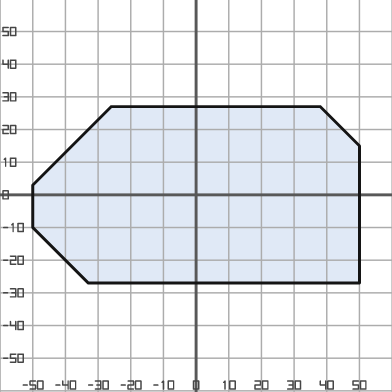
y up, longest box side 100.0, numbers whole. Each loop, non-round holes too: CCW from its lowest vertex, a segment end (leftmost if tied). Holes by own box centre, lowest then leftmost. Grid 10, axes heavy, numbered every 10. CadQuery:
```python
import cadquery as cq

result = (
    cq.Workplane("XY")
    .moveTo(-33.0, -27.0)
    .lineTo(50.0, -27.0)
    .lineTo(50.0, 15.0)
    .lineTo(38.0, 27.0)
    .lineTo(-26.0, 27.0)
    .lineTo(-50.0, 3.0)
    .lineTo(-50.0, -10.0)
    .close()
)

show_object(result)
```